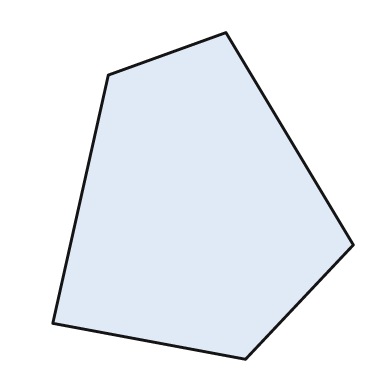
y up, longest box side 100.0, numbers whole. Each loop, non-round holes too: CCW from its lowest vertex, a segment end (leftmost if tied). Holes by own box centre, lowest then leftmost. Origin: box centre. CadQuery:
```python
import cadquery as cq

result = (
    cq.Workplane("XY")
    .moveTo(13.0, -50.0)
    .lineTo(46.0, -15.0)
    .lineTo(7.0, 50.0)
    .lineTo(-29.0, 37.0)
    .lineTo(-46.0, -39.0)
    .close()
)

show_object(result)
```